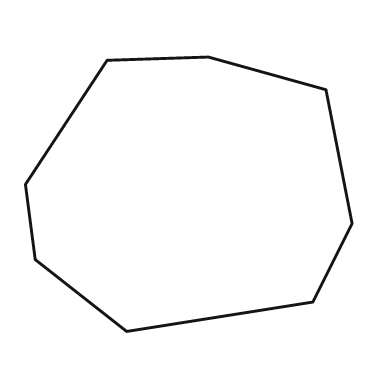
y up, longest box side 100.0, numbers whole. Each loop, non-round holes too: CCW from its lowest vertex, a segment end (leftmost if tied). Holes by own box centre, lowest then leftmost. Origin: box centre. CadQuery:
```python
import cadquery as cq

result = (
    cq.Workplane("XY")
    .moveTo(-19.0, -42.0)
    .lineTo(38.0, -33.0)
    .lineTo(50.0, -9.0)
    .lineTo(42.0, 32.0)
    .lineTo(6.0, 42.0)
    .lineTo(-25.0, 41.0)
    .lineTo(-50.0, 3.0)
    .lineTo(-47.0, -20.0)
    .close()
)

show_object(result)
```